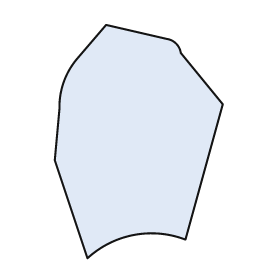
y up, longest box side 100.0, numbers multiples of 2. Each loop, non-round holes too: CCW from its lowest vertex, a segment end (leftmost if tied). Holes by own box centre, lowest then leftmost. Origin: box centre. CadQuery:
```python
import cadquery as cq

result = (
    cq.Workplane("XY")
    .moveTo(-22.0, -50.0)
    .threePointArc((-2.0, -40.0), (20.0, -42.0))
    .lineTo(36.0, 16.0)
    .lineTo(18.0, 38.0)
    .threePointArc((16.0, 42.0), (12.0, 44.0))
    .lineTo(-14.0, 50.0)
    .lineTo(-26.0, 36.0)
    .threePointArc((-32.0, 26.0), (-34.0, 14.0))
    .lineTo(-36.0, -8.0)
    .close()
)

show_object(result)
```